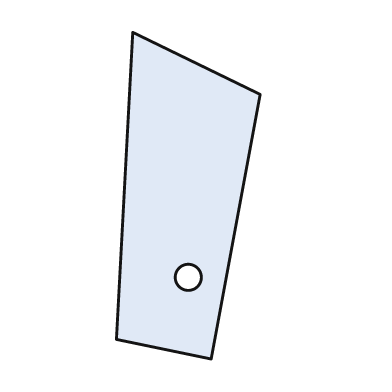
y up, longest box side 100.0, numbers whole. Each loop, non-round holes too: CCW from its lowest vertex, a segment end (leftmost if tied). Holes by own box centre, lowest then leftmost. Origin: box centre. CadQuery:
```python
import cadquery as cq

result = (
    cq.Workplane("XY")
    .moveTo(7.0, -50.0)
    .lineTo(22.0, 31.0)
    .lineTo(-17.0, 50.0)
    .lineTo(-22.0, -44.0)
    .close()
    .moveTo(0.0, -25.0)
    .circle(4.0)
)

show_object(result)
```